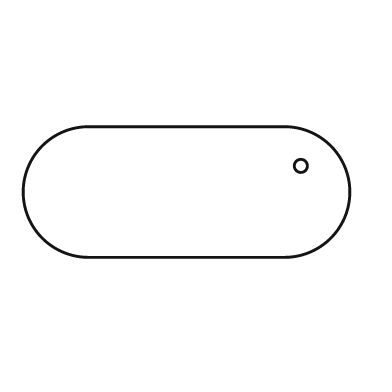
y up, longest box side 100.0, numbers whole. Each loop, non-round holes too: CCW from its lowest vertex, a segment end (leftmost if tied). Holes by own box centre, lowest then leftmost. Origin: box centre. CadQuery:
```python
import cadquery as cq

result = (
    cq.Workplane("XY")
    .moveTo(-30.0, -20.0)
    .lineTo(30.0, -20.0)
    .threePointArc((50.0, 0.0), (30.0, 20.0))
    .lineTo(-30.0, 20.0)
    .threePointArc((-50.0, 0.0), (-30.0, -20.0))
    .close()
    .moveTo(35.0, 8.0)
    .circle(2.0)
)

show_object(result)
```